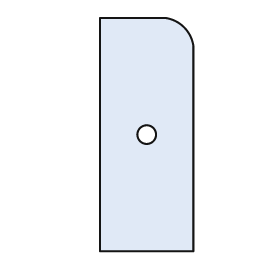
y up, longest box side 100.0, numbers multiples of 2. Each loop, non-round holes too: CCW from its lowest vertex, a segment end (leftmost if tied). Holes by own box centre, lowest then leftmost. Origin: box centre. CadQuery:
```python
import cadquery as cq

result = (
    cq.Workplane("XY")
    .moveTo(-20.0, -50.0)
    .lineTo(20.0, -50.0)
    .lineTo(20.0, 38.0)
    .threePointArc((16.0, 46.0), (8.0, 50.0))
    .lineTo(-20.0, 50.0)
    .close()
    .moveTo(0.0, 0.0)
    .circle(4.0)
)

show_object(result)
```